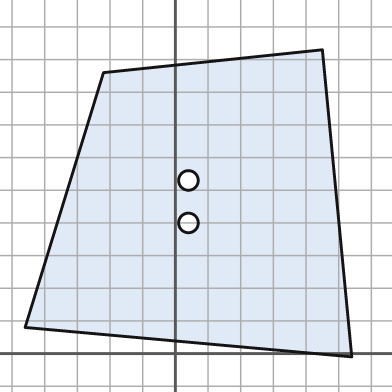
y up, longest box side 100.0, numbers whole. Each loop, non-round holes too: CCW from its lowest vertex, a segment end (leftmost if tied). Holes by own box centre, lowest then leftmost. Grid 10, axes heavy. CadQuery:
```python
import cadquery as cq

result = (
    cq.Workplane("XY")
    .moveTo(54.0, -1.0)
    .lineTo(45.0, 93.0)
    .lineTo(-22.0, 86.0)
    .lineTo(-46.0, 8.0)
    .close()
    .moveTo(4.0, 40.0)
    .circle(3.0)
    .moveTo(4.0, 53.0)
    .circle(3.0)
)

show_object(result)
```